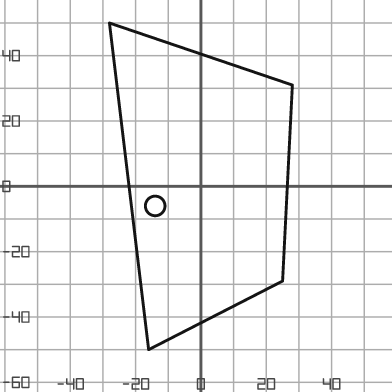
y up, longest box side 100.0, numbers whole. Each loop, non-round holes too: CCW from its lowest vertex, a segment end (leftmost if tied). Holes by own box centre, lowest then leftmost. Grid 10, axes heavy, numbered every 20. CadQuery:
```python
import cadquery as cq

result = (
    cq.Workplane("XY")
    .moveTo(-16.0, -50.0)
    .lineTo(25.0, -29.0)
    .lineTo(28.0, 31.0)
    .lineTo(-28.0, 50.0)
    .close()
    .moveTo(-14.0, -6.0)
    .circle(3.0)
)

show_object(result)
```